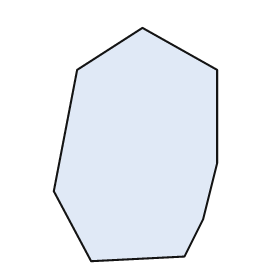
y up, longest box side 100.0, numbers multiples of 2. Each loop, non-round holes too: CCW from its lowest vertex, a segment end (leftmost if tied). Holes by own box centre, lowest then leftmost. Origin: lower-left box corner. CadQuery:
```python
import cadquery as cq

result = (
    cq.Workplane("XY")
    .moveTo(16.0, 0.0)
    .lineTo(56.0, 2.0)
    .lineTo(64.0, 18.0)
    .lineTo(70.0, 42.0)
    .lineTo(70.0, 82.0)
    .lineTo(38.0, 100.0)
    .lineTo(10.0, 82.0)
    .lineTo(0.0, 30.0)
    .close()
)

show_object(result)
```